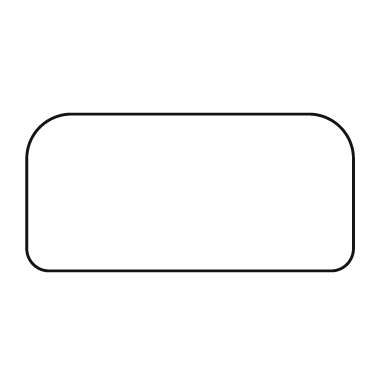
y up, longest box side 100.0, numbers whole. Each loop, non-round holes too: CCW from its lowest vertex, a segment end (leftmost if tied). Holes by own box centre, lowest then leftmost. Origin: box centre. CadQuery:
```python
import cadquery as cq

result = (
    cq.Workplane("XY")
    .moveTo(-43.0, -24.0)
    .lineTo(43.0, -24.0)
    .threePointArc((48.0, -22.0), (50.0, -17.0))
    .lineTo(50.0, 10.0)
    .threePointArc((46.0, 20.0), (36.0, 24.0))
    .lineTo(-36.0, 24.0)
    .threePointArc((-46.0, 20.0), (-50.0, 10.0))
    .lineTo(-50.0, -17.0)
    .threePointArc((-48.0, -22.0), (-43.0, -24.0))
    .close()
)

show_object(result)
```